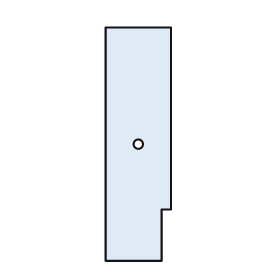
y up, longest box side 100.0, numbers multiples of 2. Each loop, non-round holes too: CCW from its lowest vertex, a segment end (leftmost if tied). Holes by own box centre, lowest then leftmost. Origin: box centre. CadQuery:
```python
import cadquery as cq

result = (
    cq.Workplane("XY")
    .moveTo(-14.0, -50.0)
    .lineTo(10.0, -50.0)
    .lineTo(10.0, -28.0)
    .lineTo(14.0, -28.0)
    .lineTo(14.0, 50.0)
    .lineTo(-14.0, 50.0)
    .close()
    .moveTo(0.0, 0.0)
    .circle(2.0)
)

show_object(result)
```